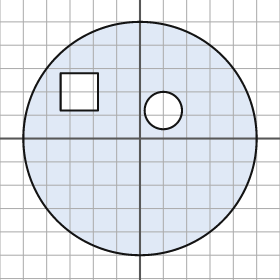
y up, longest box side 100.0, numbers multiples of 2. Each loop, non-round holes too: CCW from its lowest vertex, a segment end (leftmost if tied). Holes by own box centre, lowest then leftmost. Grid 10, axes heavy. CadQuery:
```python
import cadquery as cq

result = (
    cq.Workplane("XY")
    .moveTo(0.0, 0.0)
    .circle(50.0)
    .moveTo(10.0, 12.0)
    .circle(8.0)
    .moveTo(-34.0, 12.0)
    .lineTo(-18.0, 12.0)
    .lineTo(-18.0, 28.0)
    .lineTo(-34.0, 28.0)
    .close()
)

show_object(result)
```